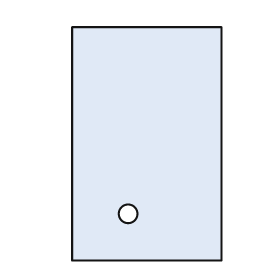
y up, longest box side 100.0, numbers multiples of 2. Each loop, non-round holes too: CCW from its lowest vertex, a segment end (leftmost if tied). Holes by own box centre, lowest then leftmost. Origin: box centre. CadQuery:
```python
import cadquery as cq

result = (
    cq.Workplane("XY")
    .moveTo(-32.0, -50.0)
    .lineTo(32.0, -50.0)
    .lineTo(32.0, 50.0)
    .lineTo(-32.0, 50.0)
    .close()
    .moveTo(-8.0, -30.0)
    .circle(4.0)
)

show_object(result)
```